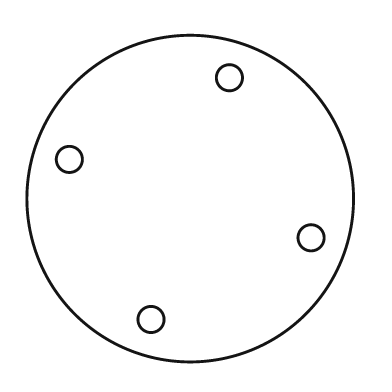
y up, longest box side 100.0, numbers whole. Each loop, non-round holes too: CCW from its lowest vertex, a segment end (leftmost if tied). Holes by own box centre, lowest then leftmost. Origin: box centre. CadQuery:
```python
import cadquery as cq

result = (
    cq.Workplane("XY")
    .moveTo(0.0, 0.0)
    .circle(50.0)
    .moveTo(-12.0, -37.0)
    .circle(4.0)
    .moveTo(37.0, -12.0)
    .circle(4.0)
    .moveTo(-37.0, 12.0)
    .circle(4.0)
    .moveTo(12.0, 37.0)
    .circle(4.0)
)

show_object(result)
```